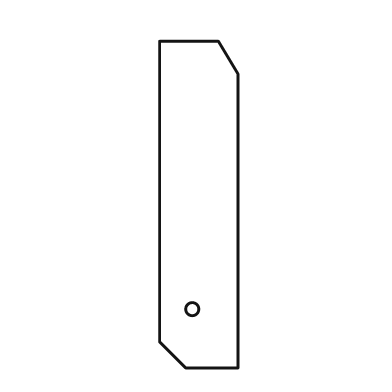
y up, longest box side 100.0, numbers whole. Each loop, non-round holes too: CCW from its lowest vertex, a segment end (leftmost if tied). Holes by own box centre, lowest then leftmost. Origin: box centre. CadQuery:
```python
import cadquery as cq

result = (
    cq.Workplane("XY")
    .moveTo(-4.0, -50.0)
    .lineTo(12.0, -50.0)
    .lineTo(12.0, 40.0)
    .lineTo(6.0, 50.0)
    .lineTo(-12.0, 50.0)
    .lineTo(-12.0, -42.0)
    .close()
    .moveTo(-2.0, -32.0)
    .circle(2.0)
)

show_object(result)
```